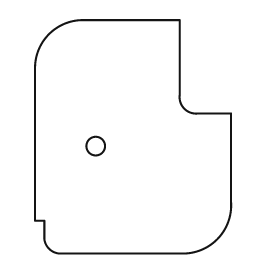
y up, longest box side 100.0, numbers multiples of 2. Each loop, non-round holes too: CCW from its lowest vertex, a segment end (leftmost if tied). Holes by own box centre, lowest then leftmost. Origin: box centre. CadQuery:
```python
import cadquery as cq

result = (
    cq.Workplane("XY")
    .moveTo(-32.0, -50.0)
    .lineTo(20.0, -50.0)
    .threePointArc((36.0, -44.0), (42.0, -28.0))
    .lineTo(42.0, 10.0)
    .lineTo(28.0, 10.0)
    .threePointArc((22.0, 12.0), (20.0, 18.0))
    .lineTo(20.0, 50.0)
    .lineTo(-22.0, 50.0)
    .threePointArc((-36.0, 44.0), (-42.0, 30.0))
    .lineTo(-42.0, -36.0)
    .lineTo(-38.0, -36.0)
    .lineTo(-38.0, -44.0)
    .threePointArc((-36.0, -48.0), (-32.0, -50.0))
    .close()
    .moveTo(-16.0, -4.0)
    .circle(4.0)
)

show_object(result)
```